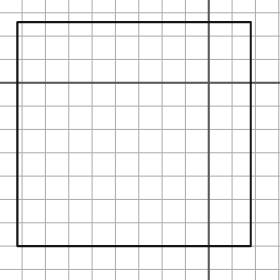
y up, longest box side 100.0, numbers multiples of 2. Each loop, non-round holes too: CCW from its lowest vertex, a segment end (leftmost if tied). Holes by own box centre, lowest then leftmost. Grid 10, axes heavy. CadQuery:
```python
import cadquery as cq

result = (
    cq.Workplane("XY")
    .moveTo(-82.0, -70.0)
    .lineTo(18.0, -70.0)
    .lineTo(18.0, 26.0)
    .lineTo(-82.0, 26.0)
    .close()
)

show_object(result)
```